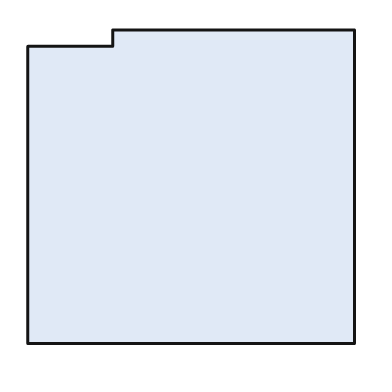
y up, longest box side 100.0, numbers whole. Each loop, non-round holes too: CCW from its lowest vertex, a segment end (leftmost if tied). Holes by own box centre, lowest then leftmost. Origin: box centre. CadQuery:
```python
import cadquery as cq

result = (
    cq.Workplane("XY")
    .moveTo(-50.0, -48.0)
    .lineTo(50.0, -48.0)
    .lineTo(50.0, 48.0)
    .lineTo(-24.0, 48.0)
    .lineTo(-24.0, 43.0)
    .lineTo(-50.0, 43.0)
    .close()
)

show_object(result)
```